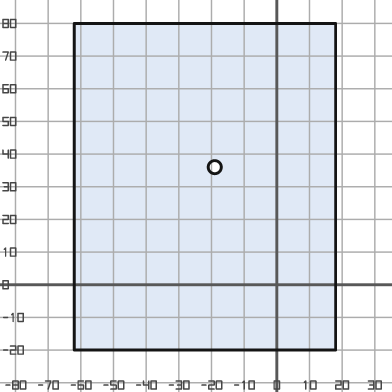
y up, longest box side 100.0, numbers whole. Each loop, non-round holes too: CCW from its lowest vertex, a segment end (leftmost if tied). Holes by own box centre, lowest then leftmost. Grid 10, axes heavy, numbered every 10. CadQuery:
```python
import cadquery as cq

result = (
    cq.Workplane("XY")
    .moveTo(-62.0, -20.0)
    .lineTo(18.0, -20.0)
    .lineTo(18.0, 80.0)
    .lineTo(-62.0, 80.0)
    .close()
    .moveTo(-19.0, 36.0)
    .circle(2.0)
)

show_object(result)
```